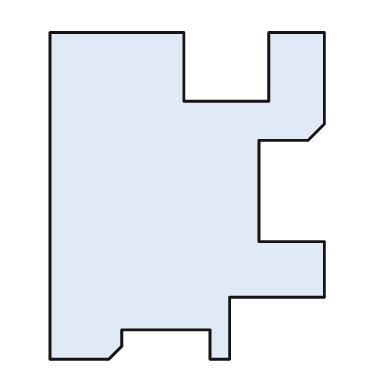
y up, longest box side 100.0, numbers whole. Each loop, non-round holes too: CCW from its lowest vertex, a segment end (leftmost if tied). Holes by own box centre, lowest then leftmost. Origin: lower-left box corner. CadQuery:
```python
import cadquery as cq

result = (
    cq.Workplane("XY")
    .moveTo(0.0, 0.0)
    .lineTo(18.0, 0.0)
    .lineTo(22.0, 4.0)
    .lineTo(22.0, 9.0)
    .lineTo(49.0, 9.0)
    .lineTo(49.0, 0.0)
    .lineTo(55.0, 0.0)
    .lineTo(55.0, 19.0)
    .lineTo(84.0, 19.0)
    .lineTo(84.0, 36.0)
    .lineTo(64.0, 36.0)
    .lineTo(64.0, 67.0)
    .lineTo(79.0, 67.0)
    .lineTo(84.0, 72.0)
    .lineTo(84.0, 100.0)
    .lineTo(67.0, 100.0)
    .lineTo(67.0, 79.0)
    .lineTo(41.0, 79.0)
    .lineTo(41.0, 100.0)
    .lineTo(0.0, 100.0)
    .close()
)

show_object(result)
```